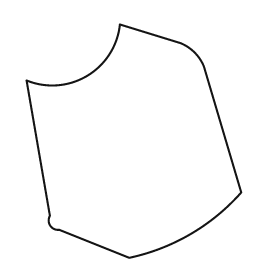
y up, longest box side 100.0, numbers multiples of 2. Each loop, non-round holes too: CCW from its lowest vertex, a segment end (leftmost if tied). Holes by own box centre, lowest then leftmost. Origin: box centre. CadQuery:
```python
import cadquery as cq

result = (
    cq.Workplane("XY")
    .moveTo(-2.0, -50.0)
    .threePointArc((24.0, -40.0), (46.0, -22.0))
    .lineTo(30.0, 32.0)
    .threePointArc((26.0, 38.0), (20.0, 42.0))
    .lineTo(-6.0, 50.0)
    .threePointArc((-20.0, 28.0), (-46.0, 26.0))
    .lineTo(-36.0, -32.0)
    .threePointArc((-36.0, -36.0), (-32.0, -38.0))
    .close()
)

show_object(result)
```